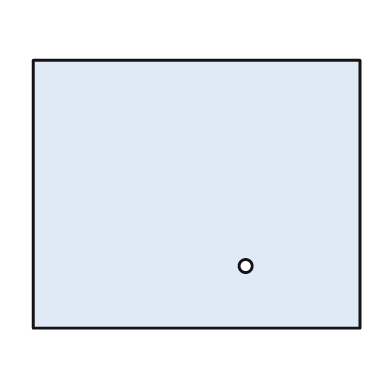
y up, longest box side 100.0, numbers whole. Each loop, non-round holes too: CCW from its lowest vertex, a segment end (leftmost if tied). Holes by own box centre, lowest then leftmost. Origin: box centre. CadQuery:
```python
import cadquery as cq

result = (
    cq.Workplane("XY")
    .moveTo(-50.0, -41.0)
    .lineTo(50.0, -41.0)
    .lineTo(50.0, 41.0)
    .lineTo(-50.0, 41.0)
    .close()
    .moveTo(15.0, -22.0)
    .circle(2.0)
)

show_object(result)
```